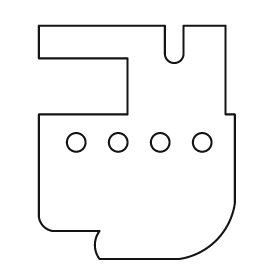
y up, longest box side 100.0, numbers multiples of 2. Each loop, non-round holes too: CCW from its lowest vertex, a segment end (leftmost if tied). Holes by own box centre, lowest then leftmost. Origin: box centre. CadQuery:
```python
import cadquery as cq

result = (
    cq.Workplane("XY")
    .moveTo(-16.0, -50.0)
    .lineTo(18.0, -50.0)
    .threePointArc((34.0, -42.0), (42.0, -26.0))
    .lineTo(42.0, 12.0)
    .lineTo(38.0, 12.0)
    .lineTo(38.0, 50.0)
    .lineTo(20.0, 50.0)
    .lineTo(20.0, 38.0)
    .threePointArc((16.0, 34.0), (12.0, 38.0))
    .lineTo(12.0, 50.0)
    .lineTo(-42.0, 50.0)
    .lineTo(-42.0, 36.0)
    .lineTo(-4.0, 36.0)
    .lineTo(-4.0, 12.0)
    .lineTo(-42.0, 12.0)
    .lineTo(-42.0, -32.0)
    .threePointArc((-40.0, -36.0), (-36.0, -38.0))
    .lineTo(-16.0, -38.0)
    .threePointArc((-18.0, -44.0), (-16.0, -50.0))
    .close()
    .moveTo(-26.0, 0.0)
    .circle(4.0)
    .moveTo(-8.0, 0.0)
    .circle(4.0)
    .moveTo(10.0, 0.0)
    .circle(4.0)
    .moveTo(28.0, 0.0)
    .circle(4.0)
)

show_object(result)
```